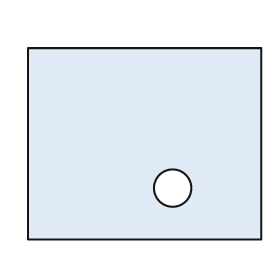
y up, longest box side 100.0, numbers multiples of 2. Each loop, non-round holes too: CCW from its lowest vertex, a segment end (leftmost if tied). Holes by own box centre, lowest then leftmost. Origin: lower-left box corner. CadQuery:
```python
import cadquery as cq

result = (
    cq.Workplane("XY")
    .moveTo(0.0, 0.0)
    .lineTo(100.0, 0.0)
    .lineTo(100.0, 82.0)
    .lineTo(0.0, 82.0)
    .close()
    .moveTo(62.0, 22.0)
    .circle(8.0)
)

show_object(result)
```